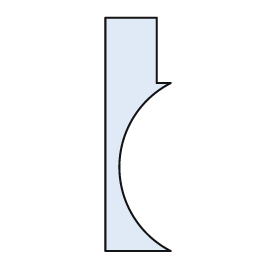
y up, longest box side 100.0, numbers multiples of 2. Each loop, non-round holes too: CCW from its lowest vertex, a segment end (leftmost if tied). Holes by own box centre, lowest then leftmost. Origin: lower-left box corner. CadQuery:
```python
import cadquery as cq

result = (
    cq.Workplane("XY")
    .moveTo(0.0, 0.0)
    .lineTo(28.0, 0.0)
    .threePointArc((6.0, 36.0), (28.0, 72.0))
    .lineTo(22.0, 72.0)
    .lineTo(22.0, 100.0)
    .lineTo(0.0, 100.0)
    .close()
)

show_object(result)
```